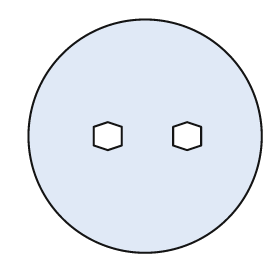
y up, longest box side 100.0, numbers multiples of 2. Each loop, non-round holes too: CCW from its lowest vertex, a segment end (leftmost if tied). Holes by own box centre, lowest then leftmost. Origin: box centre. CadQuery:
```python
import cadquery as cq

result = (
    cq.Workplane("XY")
    .moveTo(0.0, 0.0)
    .circle(50.0)
    .moveTo(-16.0, -6.0)
    .lineTo(-10.0, -4.0)
    .lineTo(-10.0, 4.0)
    .lineTo(-16.0, 6.0)
    .lineTo(-22.0, 4.0)
    .lineTo(-22.0, -4.0)
    .close()
    .moveTo(18.0, -6.0)
    .lineTo(24.0, -4.0)
    .lineTo(24.0, 4.0)
    .lineTo(18.0, 6.0)
    .lineTo(12.0, 4.0)
    .lineTo(12.0, -4.0)
    .close()
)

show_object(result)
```